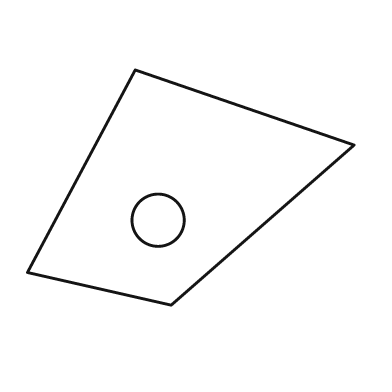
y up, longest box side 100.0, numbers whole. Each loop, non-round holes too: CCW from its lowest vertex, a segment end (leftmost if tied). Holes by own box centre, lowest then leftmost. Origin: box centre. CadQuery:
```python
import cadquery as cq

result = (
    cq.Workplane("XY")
    .moveTo(-6.0, -36.0)
    .lineTo(50.0, 13.0)
    .lineTo(-17.0, 36.0)
    .lineTo(-50.0, -26.0)
    .close()
    .moveTo(-10.0, -10.0)
    .circle(8.0)
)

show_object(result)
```